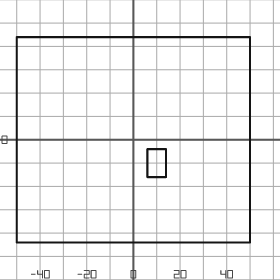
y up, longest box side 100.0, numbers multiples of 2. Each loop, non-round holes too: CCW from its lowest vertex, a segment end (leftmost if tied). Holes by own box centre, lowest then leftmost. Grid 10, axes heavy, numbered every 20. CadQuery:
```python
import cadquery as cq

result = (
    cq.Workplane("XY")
    .moveTo(-50.0, -44.0)
    .lineTo(50.0, -44.0)
    .lineTo(50.0, 44.0)
    .lineTo(-50.0, 44.0)
    .close()
    .moveTo(6.0, -16.0)
    .lineTo(14.0, -16.0)
    .lineTo(14.0, -4.0)
    .lineTo(6.0, -4.0)
    .close()
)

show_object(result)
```